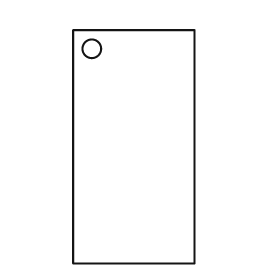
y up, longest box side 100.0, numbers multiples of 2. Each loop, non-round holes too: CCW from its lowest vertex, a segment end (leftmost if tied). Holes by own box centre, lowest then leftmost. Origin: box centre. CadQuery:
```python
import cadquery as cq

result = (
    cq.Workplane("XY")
    .moveTo(-26.0, -50.0)
    .lineTo(26.0, -50.0)
    .lineTo(26.0, 50.0)
    .lineTo(-26.0, 50.0)
    .close()
    .moveTo(-18.0, 42.0)
    .circle(4.0)
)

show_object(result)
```